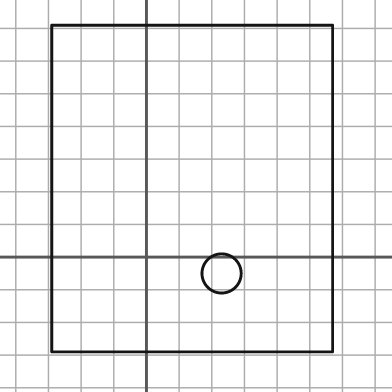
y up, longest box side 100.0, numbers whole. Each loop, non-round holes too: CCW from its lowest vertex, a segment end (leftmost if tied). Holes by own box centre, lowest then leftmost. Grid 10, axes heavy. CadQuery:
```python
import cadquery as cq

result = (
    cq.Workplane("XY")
    .moveTo(-29.0, -29.0)
    .lineTo(57.0, -29.0)
    .lineTo(57.0, 71.0)
    .lineTo(-29.0, 71.0)
    .close()
    .moveTo(23.0, -5.0)
    .circle(6.0)
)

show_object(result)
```